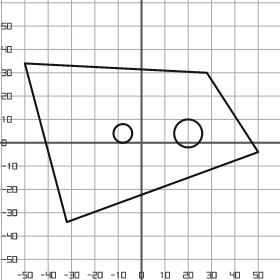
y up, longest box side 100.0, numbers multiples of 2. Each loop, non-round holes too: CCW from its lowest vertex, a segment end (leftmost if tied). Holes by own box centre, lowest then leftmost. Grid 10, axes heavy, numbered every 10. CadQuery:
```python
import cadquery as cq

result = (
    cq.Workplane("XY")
    .moveTo(-32.0, -34.0)
    .lineTo(50.0, -4.0)
    .lineTo(28.0, 30.0)
    .lineTo(-50.0, 34.0)
    .close()
    .moveTo(-8.0, 4.0)
    .circle(4.0)
    .moveTo(20.0, 4.0)
    .circle(6.0)
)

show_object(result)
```